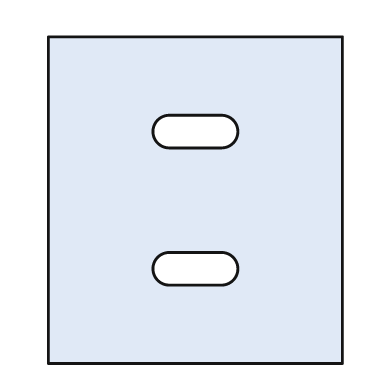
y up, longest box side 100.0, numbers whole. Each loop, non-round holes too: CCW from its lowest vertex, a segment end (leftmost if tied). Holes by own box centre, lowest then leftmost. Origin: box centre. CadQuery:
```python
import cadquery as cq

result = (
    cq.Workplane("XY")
    .moveTo(-45.0, -50.0)
    .lineTo(45.0, -50.0)
    .lineTo(45.0, 50.0)
    .lineTo(-45.0, 50.0)
    .close()
    .moveTo(-8.0, -26.0)
    .lineTo(8.0, -26.0)
    .threePointArc((13.0, -21.0), (8.0, -16.0))
    .lineTo(-8.0, -16.0)
    .threePointArc((-13.0, -21.0), (-8.0, -26.0))
    .close()
    .moveTo(-8.0, 16.0)
    .lineTo(8.0, 16.0)
    .threePointArc((13.0, 21.0), (8.0, 26.0))
    .lineTo(-8.0, 26.0)
    .threePointArc((-13.0, 21.0), (-8.0, 16.0))
    .close()
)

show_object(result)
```